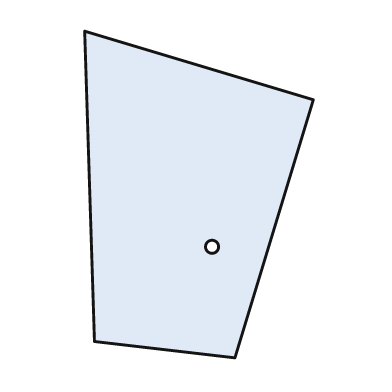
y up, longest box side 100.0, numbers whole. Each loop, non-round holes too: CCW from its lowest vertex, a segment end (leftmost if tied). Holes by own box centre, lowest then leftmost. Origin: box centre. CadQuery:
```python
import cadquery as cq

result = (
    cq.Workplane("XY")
    .moveTo(11.0, -50.0)
    .lineTo(35.0, 29.0)
    .lineTo(-35.0, 50.0)
    .lineTo(-32.0, -45.0)
    .close()
    .moveTo(4.0, -16.0)
    .circle(2.0)
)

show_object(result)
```